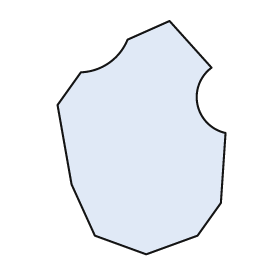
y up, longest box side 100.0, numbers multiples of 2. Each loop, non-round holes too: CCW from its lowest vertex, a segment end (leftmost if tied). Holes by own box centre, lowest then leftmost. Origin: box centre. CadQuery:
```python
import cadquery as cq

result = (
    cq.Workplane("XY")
    .moveTo(2.0, -50.0)
    .lineTo(24.0, -42.0)
    .lineTo(34.0, -28.0)
    .lineTo(36.0, 2.0)
    .threePointArc((24.0, 14.0), (30.0, 30.0))
    .lineTo(12.0, 50.0)
    .lineTo(-6.0, 42.0)
    .threePointArc((-14.0, 32.0), (-26.0, 28.0))
    .lineTo(-36.0, 14.0)
    .lineTo(-30.0, -20.0)
    .lineTo(-20.0, -42.0)
    .close()
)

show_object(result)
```